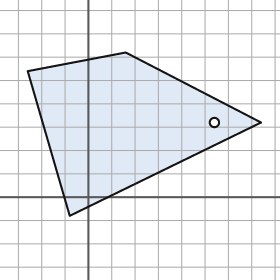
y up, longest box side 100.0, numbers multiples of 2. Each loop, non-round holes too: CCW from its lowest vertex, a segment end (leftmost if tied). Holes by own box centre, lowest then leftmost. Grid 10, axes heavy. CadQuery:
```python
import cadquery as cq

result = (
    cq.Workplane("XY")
    .moveTo(-8.0, -8.0)
    .lineTo(74.0, 32.0)
    .lineTo(16.0, 62.0)
    .lineTo(-26.0, 54.0)
    .close()
    .moveTo(54.0, 32.0)
    .circle(2.0)
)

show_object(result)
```